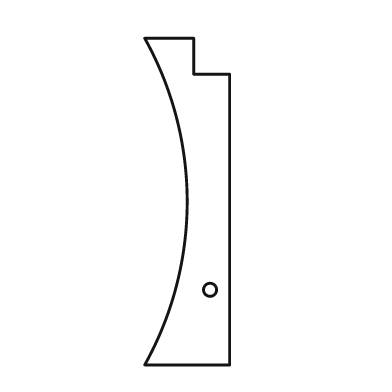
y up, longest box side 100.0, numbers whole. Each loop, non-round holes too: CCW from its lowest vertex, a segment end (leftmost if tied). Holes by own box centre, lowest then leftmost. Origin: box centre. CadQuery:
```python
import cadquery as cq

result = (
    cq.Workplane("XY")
    .moveTo(-13.0, -50.0)
    .lineTo(13.0, -50.0)
    .lineTo(13.0, 39.0)
    .lineTo(2.0, 39.0)
    .lineTo(2.0, 50.0)
    .lineTo(-13.0, 50.0)
    .threePointArc((0.0, 0.0), (-13.0, -50.0))
    .close()
    .moveTo(7.0, -27.0)
    .circle(2.0)
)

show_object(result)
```